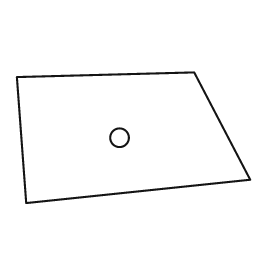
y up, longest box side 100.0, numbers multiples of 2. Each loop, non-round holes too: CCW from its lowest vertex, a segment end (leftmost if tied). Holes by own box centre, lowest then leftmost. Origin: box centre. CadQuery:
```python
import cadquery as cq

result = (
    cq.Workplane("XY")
    .moveTo(-46.0, -28.0)
    .lineTo(50.0, -18.0)
    .lineTo(26.0, 28.0)
    .lineTo(-50.0, 26.0)
    .close()
    .moveTo(-6.0, 0.0)
    .circle(4.0)
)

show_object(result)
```